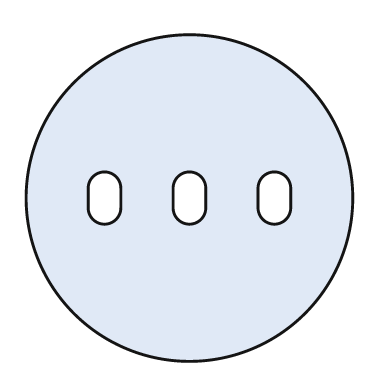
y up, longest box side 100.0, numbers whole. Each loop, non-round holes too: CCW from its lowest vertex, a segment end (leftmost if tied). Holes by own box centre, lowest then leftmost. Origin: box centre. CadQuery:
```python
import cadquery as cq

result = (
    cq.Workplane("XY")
    .moveTo(0.0, 0.0)
    .circle(50.0)
    .moveTo(-31.0, -3.0)
    .threePointArc((-26.0, -8.0), (-21.0, -3.0))
    .lineTo(-21.0, 3.0)
    .threePointArc((-26.0, 8.0), (-31.0, 3.0))
    .close()
    .moveTo(-5.0, -3.0)
    .threePointArc((0.0, -8.0), (5.0, -3.0))
    .lineTo(5.0, 3.0)
    .threePointArc((0.0, 8.0), (-5.0, 3.0))
    .close()
    .moveTo(21.0, -3.0)
    .threePointArc((26.0, -8.0), (31.0, -3.0))
    .lineTo(31.0, 3.0)
    .threePointArc((26.0, 8.0), (21.0, 3.0))
    .close()
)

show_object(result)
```